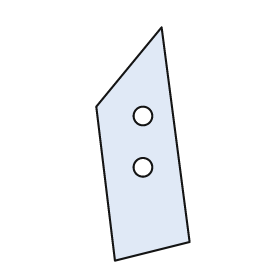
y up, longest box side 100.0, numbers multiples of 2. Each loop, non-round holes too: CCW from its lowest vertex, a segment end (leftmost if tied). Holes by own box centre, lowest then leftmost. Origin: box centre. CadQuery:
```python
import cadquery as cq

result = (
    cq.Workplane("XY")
    .moveTo(-12.0, -50.0)
    .lineTo(20.0, -42.0)
    .lineTo(8.0, 50.0)
    .lineTo(-20.0, 16.0)
    .close()
    .moveTo(0.0, -10.0)
    .circle(4.0)
    .moveTo(0.0, 12.0)
    .circle(4.0)
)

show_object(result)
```